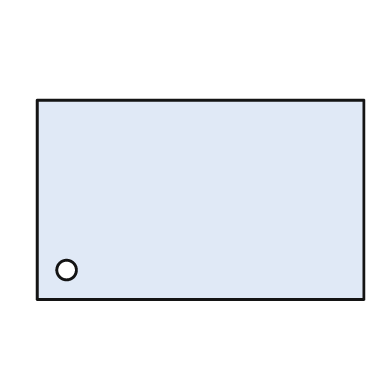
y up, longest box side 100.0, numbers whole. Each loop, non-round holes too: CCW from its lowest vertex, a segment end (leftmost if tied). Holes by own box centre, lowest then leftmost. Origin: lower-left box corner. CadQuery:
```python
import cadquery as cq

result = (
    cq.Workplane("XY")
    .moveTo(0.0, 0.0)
    .lineTo(100.0, 0.0)
    .lineTo(100.0, 61.0)
    .lineTo(0.0, 61.0)
    .close()
    .moveTo(9.0, 9.0)
    .circle(3.0)
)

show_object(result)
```